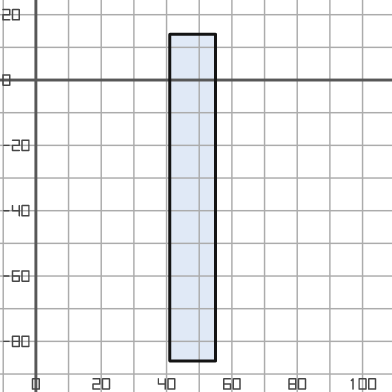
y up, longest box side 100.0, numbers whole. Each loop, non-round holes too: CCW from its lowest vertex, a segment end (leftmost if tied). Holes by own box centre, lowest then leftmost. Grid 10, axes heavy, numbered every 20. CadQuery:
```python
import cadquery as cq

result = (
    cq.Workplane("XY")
    .moveTo(41.0, -86.0)
    .lineTo(55.0, -86.0)
    .lineTo(55.0, 14.0)
    .lineTo(41.0, 14.0)
    .close()
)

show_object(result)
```